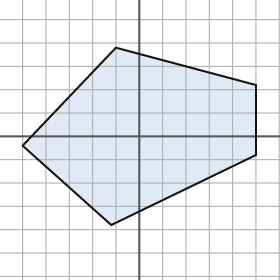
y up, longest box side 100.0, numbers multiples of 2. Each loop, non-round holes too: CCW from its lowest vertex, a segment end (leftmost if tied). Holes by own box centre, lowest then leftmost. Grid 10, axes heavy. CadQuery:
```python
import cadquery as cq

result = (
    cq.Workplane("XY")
    .moveTo(-12.0, -38.0)
    .lineTo(50.0, -8.0)
    .lineTo(50.0, 22.0)
    .lineTo(-10.0, 38.0)
    .lineTo(-50.0, -4.0)
    .close()
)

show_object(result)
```